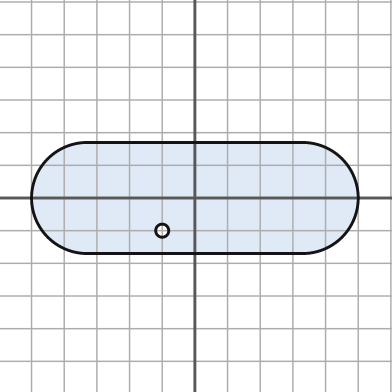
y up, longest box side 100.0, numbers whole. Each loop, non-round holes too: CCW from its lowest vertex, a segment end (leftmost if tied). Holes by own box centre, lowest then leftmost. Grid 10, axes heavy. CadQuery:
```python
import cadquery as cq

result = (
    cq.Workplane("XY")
    .moveTo(-33.0, -17.0)
    .lineTo(33.0, -17.0)
    .threePointArc((50.0, 0.0), (33.0, 17.0))
    .lineTo(-33.0, 17.0)
    .threePointArc((-50.0, 0.0), (-33.0, -17.0))
    .close()
    .moveTo(-10.0, -10.0)
    .circle(2.0)
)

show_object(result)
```